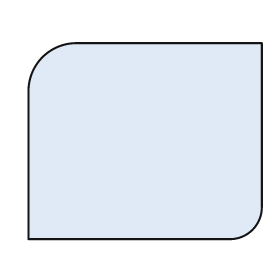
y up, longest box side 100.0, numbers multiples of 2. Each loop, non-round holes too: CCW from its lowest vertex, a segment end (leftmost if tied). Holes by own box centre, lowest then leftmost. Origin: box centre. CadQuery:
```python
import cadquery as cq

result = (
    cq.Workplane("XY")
    .moveTo(-50.0, -42.0)
    .lineTo(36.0, -42.0)
    .threePointArc((46.0, -38.0), (50.0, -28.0))
    .lineTo(50.0, 42.0)
    .lineTo(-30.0, 42.0)
    .threePointArc((-44.0, 36.0), (-50.0, 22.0))
    .close()
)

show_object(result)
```